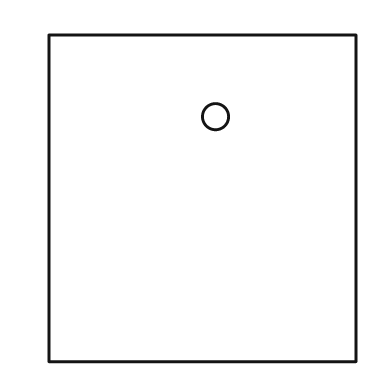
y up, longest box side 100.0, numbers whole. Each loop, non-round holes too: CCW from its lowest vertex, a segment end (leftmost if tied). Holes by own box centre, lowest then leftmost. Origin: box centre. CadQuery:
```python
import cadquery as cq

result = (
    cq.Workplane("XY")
    .moveTo(-47.0, -50.0)
    .lineTo(47.0, -50.0)
    .lineTo(47.0, 50.0)
    .lineTo(-47.0, 50.0)
    .close()
    .moveTo(4.0, 25.0)
    .circle(4.0)
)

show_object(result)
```